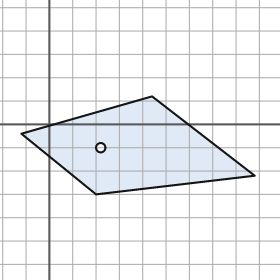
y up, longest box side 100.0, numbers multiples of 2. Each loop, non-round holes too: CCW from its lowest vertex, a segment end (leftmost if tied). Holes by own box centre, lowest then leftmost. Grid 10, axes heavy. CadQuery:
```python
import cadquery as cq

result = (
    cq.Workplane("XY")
    .moveTo(20.0, -30.0)
    .lineTo(88.0, -22.0)
    .lineTo(44.0, 12.0)
    .lineTo(-12.0, -4.0)
    .close()
    .moveTo(22.0, -10.0)
    .circle(2.0)
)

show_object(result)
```